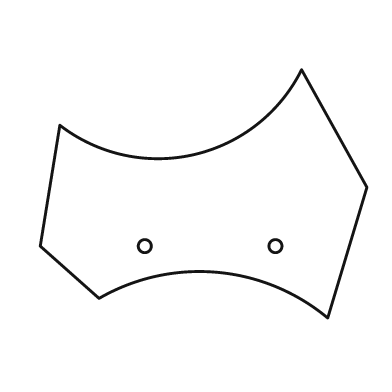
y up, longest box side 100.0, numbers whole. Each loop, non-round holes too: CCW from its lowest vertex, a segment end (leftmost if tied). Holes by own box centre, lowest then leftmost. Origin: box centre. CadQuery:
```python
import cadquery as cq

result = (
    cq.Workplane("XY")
    .moveTo(38.0, -38.0)
    .lineTo(50.0, 2.0)
    .lineTo(30.0, 38.0)
    .threePointArc((-3.0, 12.0), (-44.0, 21.0))
    .lineTo(-50.0, -16.0)
    .lineTo(-32.0, -32.0)
    .threePointArc((4.0, -24.0), (38.0, -38.0))
    .close()
    .moveTo(-18.0, -16.0)
    .circle(2.0)
    .moveTo(22.0, -16.0)
    .circle(2.0)
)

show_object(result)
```